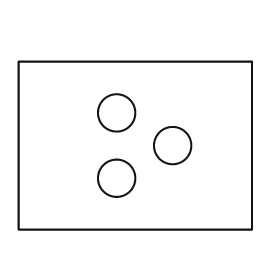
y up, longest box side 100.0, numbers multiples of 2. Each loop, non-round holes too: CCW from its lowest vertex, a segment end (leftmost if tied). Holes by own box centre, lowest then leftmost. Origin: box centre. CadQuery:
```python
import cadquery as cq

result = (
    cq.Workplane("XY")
    .moveTo(-50.0, -36.0)
    .lineTo(50.0, -36.0)
    .lineTo(50.0, 36.0)
    .lineTo(-50.0, 36.0)
    .close()
    .moveTo(-8.0, -14.0)
    .circle(8.0)
    .moveTo(16.0, 0.0)
    .circle(8.0)
    .moveTo(-8.0, 14.0)
    .circle(8.0)
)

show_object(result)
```